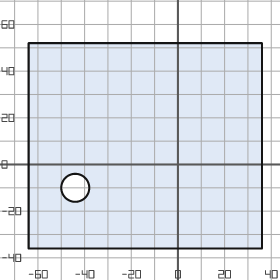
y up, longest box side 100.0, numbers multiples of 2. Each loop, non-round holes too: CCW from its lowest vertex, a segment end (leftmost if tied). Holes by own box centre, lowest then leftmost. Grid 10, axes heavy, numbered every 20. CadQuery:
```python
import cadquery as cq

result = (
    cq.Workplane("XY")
    .moveTo(-64.0, -36.0)
    .lineTo(36.0, -36.0)
    .lineTo(36.0, 52.0)
    .lineTo(-64.0, 52.0)
    .close()
    .moveTo(-44.0, -10.0)
    .circle(6.0)
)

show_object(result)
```